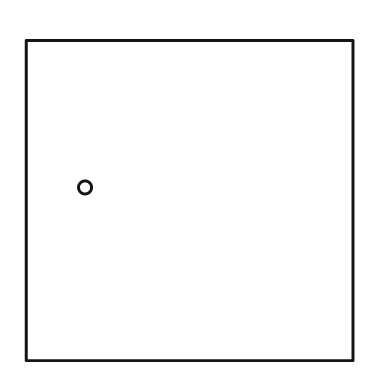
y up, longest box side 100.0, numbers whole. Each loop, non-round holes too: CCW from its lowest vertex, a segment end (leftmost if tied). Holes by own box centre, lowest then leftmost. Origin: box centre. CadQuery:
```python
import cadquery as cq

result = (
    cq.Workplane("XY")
    .moveTo(-50.0, -49.0)
    .lineTo(50.0, -49.0)
    .lineTo(50.0, 49.0)
    .lineTo(-50.0, 49.0)
    .close()
    .moveTo(-32.0, 4.0)
    .circle(2.0)
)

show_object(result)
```